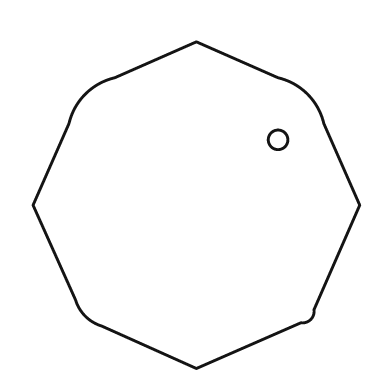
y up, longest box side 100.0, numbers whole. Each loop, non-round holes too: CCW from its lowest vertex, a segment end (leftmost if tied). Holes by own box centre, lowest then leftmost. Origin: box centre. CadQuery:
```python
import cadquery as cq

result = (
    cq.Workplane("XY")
    .moveTo(0.0, -50.0)
    .lineTo(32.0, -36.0)
    .threePointArc((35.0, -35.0), (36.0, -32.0))
    .lineTo(50.0, 0.0)
    .lineTo(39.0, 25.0)
    .threePointArc((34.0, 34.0), (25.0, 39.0))
    .lineTo(0.0, 50.0)
    .lineTo(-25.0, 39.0)
    .threePointArc((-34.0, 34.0), (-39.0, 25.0))
    .lineTo(-50.0, 0.0)
    .lineTo(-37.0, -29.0)
    .threePointArc((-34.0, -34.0), (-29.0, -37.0))
    .close()
    .moveTo(25.0, 20.0)
    .circle(3.0)
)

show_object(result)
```